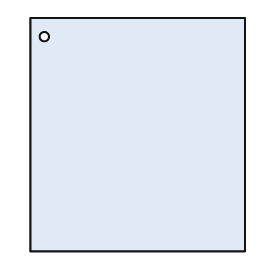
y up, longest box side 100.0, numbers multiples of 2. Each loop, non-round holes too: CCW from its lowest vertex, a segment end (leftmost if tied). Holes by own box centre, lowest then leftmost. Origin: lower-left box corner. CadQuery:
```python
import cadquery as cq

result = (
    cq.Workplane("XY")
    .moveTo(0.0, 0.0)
    .lineTo(92.0, 0.0)
    .lineTo(92.0, 100.0)
    .lineTo(0.0, 100.0)
    .close()
    .moveTo(6.0, 92.0)
    .circle(2.0)
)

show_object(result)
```